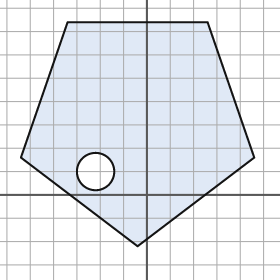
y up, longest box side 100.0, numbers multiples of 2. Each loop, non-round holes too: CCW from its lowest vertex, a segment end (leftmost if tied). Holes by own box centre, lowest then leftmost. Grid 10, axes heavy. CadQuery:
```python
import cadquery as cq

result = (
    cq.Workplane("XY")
    .moveTo(-4.0, -22.0)
    .lineTo(46.0, 16.0)
    .lineTo(26.0, 74.0)
    .lineTo(-34.0, 74.0)
    .lineTo(-54.0, 16.0)
    .close()
    .moveTo(-22.0, 10.0)
    .circle(8.0)
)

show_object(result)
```